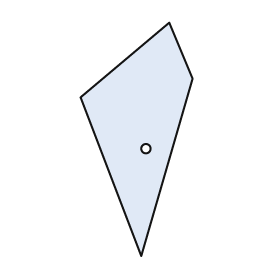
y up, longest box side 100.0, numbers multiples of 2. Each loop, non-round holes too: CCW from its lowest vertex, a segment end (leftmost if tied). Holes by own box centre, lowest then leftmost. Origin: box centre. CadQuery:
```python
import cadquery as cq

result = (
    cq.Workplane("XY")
    .moveTo(2.0, -50.0)
    .lineTo(24.0, 26.0)
    .lineTo(14.0, 50.0)
    .lineTo(-24.0, 18.0)
    .close()
    .moveTo(4.0, -4.0)
    .circle(2.0)
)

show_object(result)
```